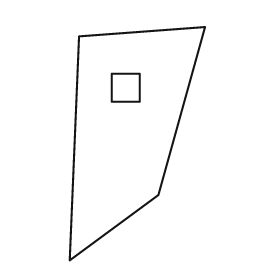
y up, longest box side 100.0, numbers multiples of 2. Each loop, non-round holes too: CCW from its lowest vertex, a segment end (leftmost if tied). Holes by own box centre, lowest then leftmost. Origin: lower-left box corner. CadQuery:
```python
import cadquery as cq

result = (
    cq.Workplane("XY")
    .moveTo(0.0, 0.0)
    .lineTo(38.0, 28.0)
    .lineTo(58.0, 100.0)
    .lineTo(4.0, 96.0)
    .close()
    .moveTo(18.0, 68.0)
    .lineTo(30.0, 68.0)
    .lineTo(30.0, 80.0)
    .lineTo(18.0, 80.0)
    .close()
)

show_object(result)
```